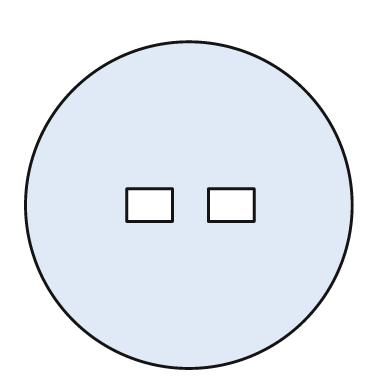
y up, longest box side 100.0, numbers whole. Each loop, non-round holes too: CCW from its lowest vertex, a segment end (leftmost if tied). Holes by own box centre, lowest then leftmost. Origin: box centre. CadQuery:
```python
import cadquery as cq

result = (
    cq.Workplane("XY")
    .moveTo(0.0, 0.0)
    .circle(50.0)
    .moveTo(-19.0, -5.0)
    .lineTo(-5.0, -5.0)
    .lineTo(-5.0, 5.0)
    .lineTo(-19.0, 5.0)
    .close()
    .moveTo(6.0, -5.0)
    .lineTo(20.0, -5.0)
    .lineTo(20.0, 5.0)
    .lineTo(6.0, 5.0)
    .close()
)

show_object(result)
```